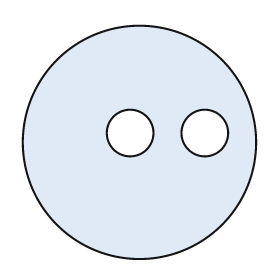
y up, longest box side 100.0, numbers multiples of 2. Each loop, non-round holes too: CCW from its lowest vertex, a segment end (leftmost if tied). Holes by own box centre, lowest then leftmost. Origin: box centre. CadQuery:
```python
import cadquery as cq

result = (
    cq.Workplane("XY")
    .moveTo(0.0, 0.0)
    .circle(50.0)
    .moveTo(-4.0, 4.0)
    .circle(10.0)
    .moveTo(28.0, 4.0)
    .circle(10.0)
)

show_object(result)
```